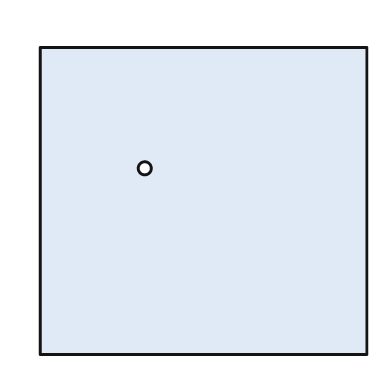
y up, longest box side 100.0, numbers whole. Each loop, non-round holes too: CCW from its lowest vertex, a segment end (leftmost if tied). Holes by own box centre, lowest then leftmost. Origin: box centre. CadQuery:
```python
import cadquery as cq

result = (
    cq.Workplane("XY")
    .moveTo(-50.0, -47.0)
    .lineTo(50.0, -47.0)
    .lineTo(50.0, 47.0)
    .lineTo(-50.0, 47.0)
    .close()
    .moveTo(-18.0, 10.0)
    .circle(2.0)
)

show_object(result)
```